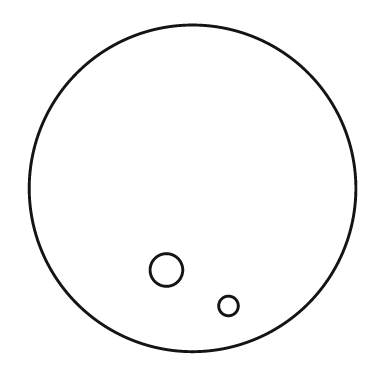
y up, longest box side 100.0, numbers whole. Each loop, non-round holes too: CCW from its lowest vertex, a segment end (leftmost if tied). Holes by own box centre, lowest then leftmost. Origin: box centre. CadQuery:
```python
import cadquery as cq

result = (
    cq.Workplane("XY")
    .moveTo(0.0, 0.0)
    .circle(50.0)
    .moveTo(11.0, -36.0)
    .circle(3.0)
    .moveTo(-8.0, -25.0)
    .circle(5.0)
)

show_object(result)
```